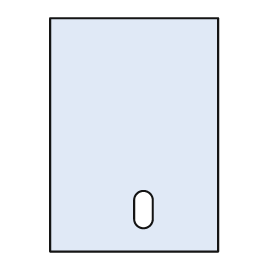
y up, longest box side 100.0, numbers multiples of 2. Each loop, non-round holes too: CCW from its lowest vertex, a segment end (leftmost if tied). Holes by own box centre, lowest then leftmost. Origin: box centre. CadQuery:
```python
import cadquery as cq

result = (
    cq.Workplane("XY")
    .moveTo(-36.0, -50.0)
    .lineTo(36.0, -50.0)
    .lineTo(36.0, 50.0)
    .lineTo(-36.0, 50.0)
    .close()
    .moveTo(0.0, -36.0)
    .threePointArc((4.0, -40.0), (8.0, -36.0))
    .lineTo(8.0, -28.0)
    .threePointArc((4.0, -24.0), (0.0, -28.0))
    .close()
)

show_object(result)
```